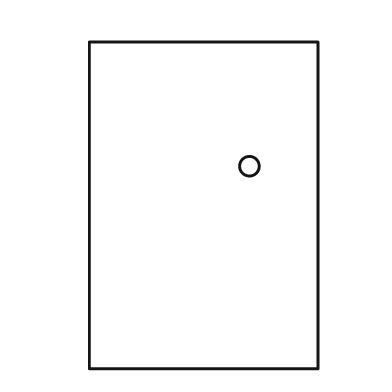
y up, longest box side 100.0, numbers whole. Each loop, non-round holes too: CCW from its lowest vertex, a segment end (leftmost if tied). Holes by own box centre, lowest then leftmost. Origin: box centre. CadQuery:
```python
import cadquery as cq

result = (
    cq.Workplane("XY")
    .moveTo(-35.0, -50.0)
    .lineTo(35.0, -50.0)
    .lineTo(35.0, 50.0)
    .lineTo(-35.0, 50.0)
    .close()
    .moveTo(14.0, 12.0)
    .circle(3.0)
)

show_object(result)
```